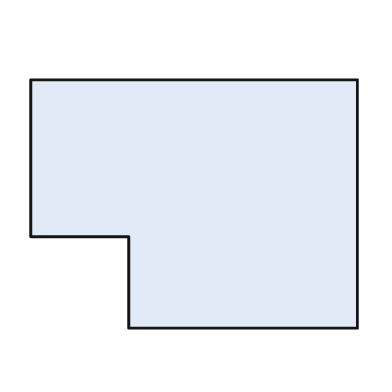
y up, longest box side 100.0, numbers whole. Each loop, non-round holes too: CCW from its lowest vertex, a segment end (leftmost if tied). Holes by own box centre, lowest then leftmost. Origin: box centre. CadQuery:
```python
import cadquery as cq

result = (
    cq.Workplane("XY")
    .moveTo(-20.0, -38.0)
    .lineTo(50.0, -38.0)
    .lineTo(50.0, 38.0)
    .lineTo(-50.0, 38.0)
    .lineTo(-50.0, -10.0)
    .lineTo(-20.0, -10.0)
    .close()
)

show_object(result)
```